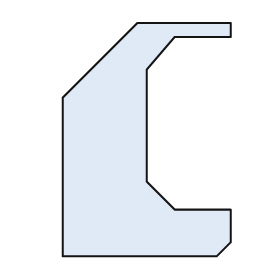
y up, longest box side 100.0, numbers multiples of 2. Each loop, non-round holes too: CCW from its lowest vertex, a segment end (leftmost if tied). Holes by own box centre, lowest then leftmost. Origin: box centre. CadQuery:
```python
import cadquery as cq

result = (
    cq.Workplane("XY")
    .moveTo(-36.0, -50.0)
    .lineTo(30.0, -50.0)
    .lineTo(36.0, -44.0)
    .lineTo(36.0, -30.0)
    .lineTo(12.0, -30.0)
    .lineTo(0.0, -18.0)
    .lineTo(0.0, 30.0)
    .lineTo(12.0, 44.0)
    .lineTo(36.0, 44.0)
    .lineTo(36.0, 50.0)
    .lineTo(-4.0, 50.0)
    .lineTo(-36.0, 18.0)
    .close()
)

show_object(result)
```